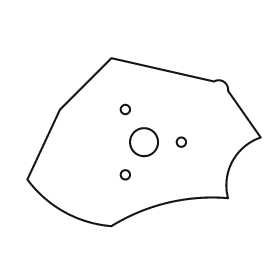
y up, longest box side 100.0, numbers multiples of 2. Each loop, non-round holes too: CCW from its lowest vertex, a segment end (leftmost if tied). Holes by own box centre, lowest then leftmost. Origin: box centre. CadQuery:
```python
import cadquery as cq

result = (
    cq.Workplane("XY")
    .moveTo(-14.0, -36.0)
    .threePointArc((10.0, -26.0), (36.0, -24.0))
    .threePointArc((38.0, -8.0), (50.0, 2.0))
    .lineTo(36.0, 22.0)
    .threePointArc((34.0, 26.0), (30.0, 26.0))
    .lineTo(-14.0, 36.0)
    .lineTo(-36.0, 14.0)
    .lineTo(-50.0, -16.0)
    .threePointArc((-34.0, -30.0), (-14.0, -36.0))
    .close()
    .moveTo(-8.0, -14.0)
    .circle(2.0)
    .moveTo(0.0, 0.0)
    .circle(6.0)
    .moveTo(16.0, 0.0)
    .circle(2.0)
    .moveTo(-8.0, 14.0)
    .circle(2.0)
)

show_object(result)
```